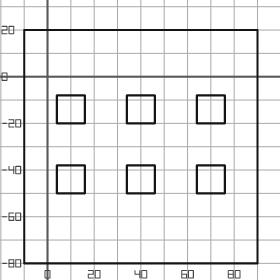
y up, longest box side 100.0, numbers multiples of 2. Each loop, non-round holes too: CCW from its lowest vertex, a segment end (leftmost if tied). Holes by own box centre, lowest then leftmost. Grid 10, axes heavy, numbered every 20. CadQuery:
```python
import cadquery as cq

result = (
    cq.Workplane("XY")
    .moveTo(-10.0, -80.0)
    .lineTo(90.0, -80.0)
    .lineTo(90.0, 20.0)
    .lineTo(-10.0, 20.0)
    .close()
    .moveTo(4.0, -50.0)
    .lineTo(16.0, -50.0)
    .lineTo(16.0, -38.0)
    .lineTo(4.0, -38.0)
    .close()
    .moveTo(34.0, -50.0)
    .lineTo(46.0, -50.0)
    .lineTo(46.0, -38.0)
    .lineTo(34.0, -38.0)
    .close()
    .moveTo(64.0, -50.0)
    .lineTo(76.0, -50.0)
    .lineTo(76.0, -38.0)
    .lineTo(64.0, -38.0)
    .close()
    .moveTo(4.0, -20.0)
    .lineTo(16.0, -20.0)
    .lineTo(16.0, -8.0)
    .lineTo(4.0, -8.0)
    .close()
    .moveTo(34.0, -20.0)
    .lineTo(46.0, -20.0)
    .lineTo(46.0, -8.0)
    .lineTo(34.0, -8.0)
    .close()
    .moveTo(64.0, -20.0)
    .lineTo(76.0, -20.0)
    .lineTo(76.0, -8.0)
    .lineTo(64.0, -8.0)
    .close()
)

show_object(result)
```